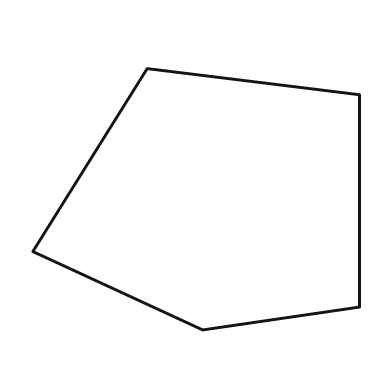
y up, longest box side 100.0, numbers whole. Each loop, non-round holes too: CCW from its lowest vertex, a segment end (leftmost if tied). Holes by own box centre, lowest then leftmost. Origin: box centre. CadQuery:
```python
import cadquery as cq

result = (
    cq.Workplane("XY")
    .moveTo(2.0, -40.0)
    .lineTo(50.0, -33.0)
    .lineTo(50.0, 32.0)
    .lineTo(-15.0, 40.0)
    .lineTo(-50.0, -16.0)
    .close()
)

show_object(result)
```